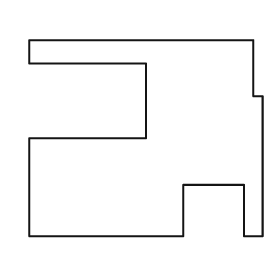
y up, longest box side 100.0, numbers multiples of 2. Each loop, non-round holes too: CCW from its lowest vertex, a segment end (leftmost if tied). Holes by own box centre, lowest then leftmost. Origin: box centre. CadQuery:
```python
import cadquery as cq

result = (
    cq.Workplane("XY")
    .moveTo(-50.0, -42.0)
    .lineTo(16.0, -42.0)
    .lineTo(16.0, -20.0)
    .lineTo(42.0, -20.0)
    .lineTo(42.0, -42.0)
    .lineTo(50.0, -42.0)
    .lineTo(50.0, 18.0)
    .lineTo(46.0, 18.0)
    .lineTo(46.0, 42.0)
    .lineTo(-50.0, 42.0)
    .lineTo(-50.0, 32.0)
    .lineTo(0.0, 32.0)
    .lineTo(0.0, 0.0)
    .lineTo(-50.0, 0.0)
    .close()
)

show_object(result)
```